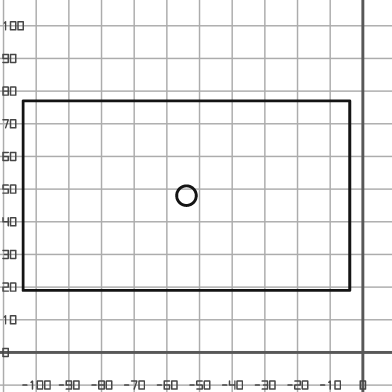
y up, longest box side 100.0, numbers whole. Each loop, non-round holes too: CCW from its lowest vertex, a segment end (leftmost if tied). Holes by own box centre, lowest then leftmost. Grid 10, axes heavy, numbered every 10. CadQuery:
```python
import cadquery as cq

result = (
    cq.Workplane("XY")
    .moveTo(-104.0, 19.0)
    .lineTo(-4.0, 19.0)
    .lineTo(-4.0, 77.0)
    .lineTo(-104.0, 77.0)
    .close()
    .moveTo(-54.0, 48.0)
    .circle(3.0)
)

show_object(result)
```